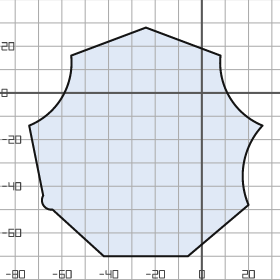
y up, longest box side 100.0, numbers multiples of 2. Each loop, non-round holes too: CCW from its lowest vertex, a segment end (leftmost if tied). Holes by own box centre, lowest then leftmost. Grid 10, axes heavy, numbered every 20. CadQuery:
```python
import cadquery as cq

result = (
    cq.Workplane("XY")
    .moveTo(-42.0, -70.0)
    .lineTo(-6.0, -70.0)
    .lineTo(20.0, -48.0)
    .threePointArc((18.0, -30.0), (26.0, -14.0))
    .threePointArc((12.0, -2.0), (8.0, 16.0))
    .lineTo(-24.0, 28.0)
    .lineTo(-56.0, 16.0)
    .threePointArc((-60.0, -2.0), (-74.0, -14.0))
    .lineTo(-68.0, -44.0)
    .threePointArc((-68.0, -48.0), (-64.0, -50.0))
    .close()
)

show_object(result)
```